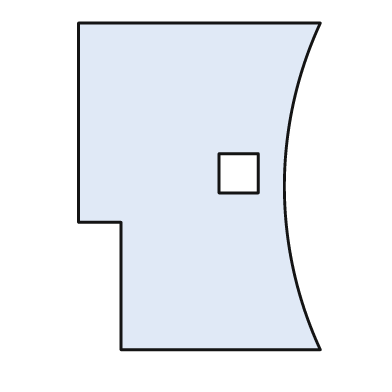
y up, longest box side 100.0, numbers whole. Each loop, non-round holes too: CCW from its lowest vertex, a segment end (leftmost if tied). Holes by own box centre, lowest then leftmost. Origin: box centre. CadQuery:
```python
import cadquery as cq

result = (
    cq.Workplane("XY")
    .moveTo(-24.0, -50.0)
    .lineTo(37.0, -50.0)
    .threePointArc((26.0, 0.0), (37.0, 50.0))
    .lineTo(-37.0, 50.0)
    .lineTo(-37.0, -11.0)
    .lineTo(-24.0, -11.0)
    .close()
    .moveTo(6.0, -2.0)
    .lineTo(18.0, -2.0)
    .lineTo(18.0, 10.0)
    .lineTo(6.0, 10.0)
    .close()
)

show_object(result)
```